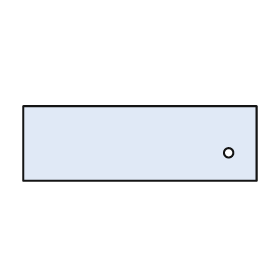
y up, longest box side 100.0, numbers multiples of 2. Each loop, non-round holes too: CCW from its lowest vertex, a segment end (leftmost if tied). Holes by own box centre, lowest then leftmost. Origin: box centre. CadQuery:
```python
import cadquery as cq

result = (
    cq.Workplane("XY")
    .moveTo(-50.0, -16.0)
    .lineTo(50.0, -16.0)
    .lineTo(50.0, 16.0)
    .lineTo(-50.0, 16.0)
    .close()
    .moveTo(38.0, -4.0)
    .circle(2.0)
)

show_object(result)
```